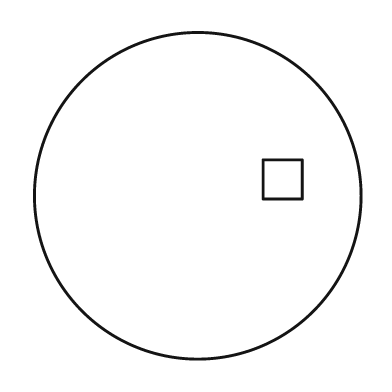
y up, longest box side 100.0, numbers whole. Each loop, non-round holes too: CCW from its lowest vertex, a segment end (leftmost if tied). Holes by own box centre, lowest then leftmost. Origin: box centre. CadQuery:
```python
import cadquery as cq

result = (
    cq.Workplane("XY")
    .moveTo(0.0, 0.0)
    .circle(50.0)
    .moveTo(20.0, -1.0)
    .lineTo(32.0, -1.0)
    .lineTo(32.0, 11.0)
    .lineTo(20.0, 11.0)
    .close()
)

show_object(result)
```